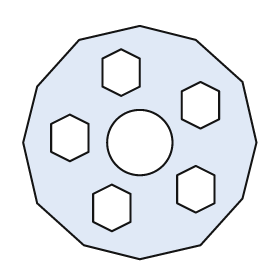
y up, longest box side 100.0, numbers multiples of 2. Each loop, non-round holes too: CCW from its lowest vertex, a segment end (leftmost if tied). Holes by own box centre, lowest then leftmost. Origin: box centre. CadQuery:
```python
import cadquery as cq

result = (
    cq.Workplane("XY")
    .moveTo(0.0, -50.0)
    .lineTo(26.0, -44.0)
    .lineTo(44.0, -24.0)
    .lineTo(50.0, 0.0)
    .lineTo(44.0, 26.0)
    .lineTo(24.0, 44.0)
    .lineTo(0.0, 50.0)
    .lineTo(-26.0, 44.0)
    .lineTo(-44.0, 24.0)
    .lineTo(-50.0, 0.0)
    .lineTo(-44.0, -26.0)
    .lineTo(-24.0, -44.0)
    .close()
    .moveTo(-12.0, -38.0)
    .lineTo(-4.0, -34.0)
    .lineTo(-4.0, -22.0)
    .lineTo(-12.0, -18.0)
    .lineTo(-20.0, -22.0)
    .lineTo(-20.0, -34.0)
    .close()
    .moveTo(24.0, -30.0)
    .lineTo(32.0, -26.0)
    .lineTo(32.0, -14.0)
    .lineTo(24.0, -10.0)
    .lineTo(16.0, -14.0)
    .lineTo(16.0, -26.0)
    .close()
    .moveTo(0.0, 0.0)
    .circle(14.0)
    .moveTo(-30.0, -8.0)
    .lineTo(-22.0, -4.0)
    .lineTo(-22.0, 8.0)
    .lineTo(-30.0, 12.0)
    .lineTo(-38.0, 8.0)
    .lineTo(-38.0, -4.0)
    .close()
    .moveTo(26.0, 6.0)
    .lineTo(34.0, 10.0)
    .lineTo(34.0, 22.0)
    .lineTo(26.0, 26.0)
    .lineTo(18.0, 22.0)
    .lineTo(18.0, 10.0)
    .close()
    .moveTo(-8.0, 20.0)
    .lineTo(0.0, 24.0)
    .lineTo(0.0, 36.0)
    .lineTo(-8.0, 40.0)
    .lineTo(-16.0, 36.0)
    .lineTo(-16.0, 24.0)
    .close()
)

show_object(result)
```